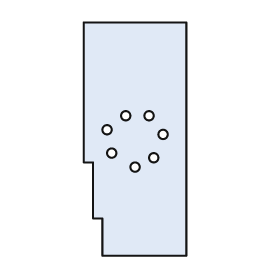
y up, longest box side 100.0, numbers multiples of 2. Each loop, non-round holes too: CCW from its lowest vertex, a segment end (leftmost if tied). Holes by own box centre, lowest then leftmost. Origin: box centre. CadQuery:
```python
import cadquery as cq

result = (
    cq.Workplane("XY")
    .moveTo(-14.0, -50.0)
    .lineTo(22.0, -50.0)
    .lineTo(22.0, 50.0)
    .lineTo(-22.0, 50.0)
    .lineTo(-22.0, -10.0)
    .lineTo(-18.0, -10.0)
    .lineTo(-18.0, -34.0)
    .lineTo(-14.0, -34.0)
    .close()
    .moveTo(0.0, -12.0)
    .circle(2.0)
    .moveTo(8.0, -8.0)
    .circle(2.0)
    .moveTo(-10.0, -6.0)
    .circle(2.0)
    .moveTo(12.0, 2.0)
    .circle(2.0)
    .moveTo(-12.0, 4.0)
    .circle(2.0)
    .moveTo(-4.0, 10.0)
    .circle(2.0)
    .moveTo(6.0, 10.0)
    .circle(2.0)
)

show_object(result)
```